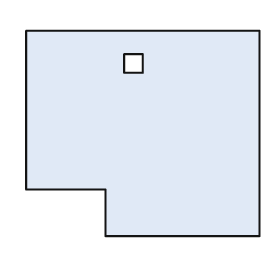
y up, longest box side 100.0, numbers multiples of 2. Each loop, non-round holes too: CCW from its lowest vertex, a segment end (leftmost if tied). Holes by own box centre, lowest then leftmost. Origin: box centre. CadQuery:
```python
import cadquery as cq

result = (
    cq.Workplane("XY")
    .moveTo(-16.0, -44.0)
    .lineTo(50.0, -44.0)
    .lineTo(50.0, 44.0)
    .lineTo(-50.0, 44.0)
    .lineTo(-50.0, -24.0)
    .lineTo(-16.0, -24.0)
    .close()
    .moveTo(-8.0, 26.0)
    .lineTo(0.0, 26.0)
    .lineTo(0.0, 34.0)
    .lineTo(-8.0, 34.0)
    .close()
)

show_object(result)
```